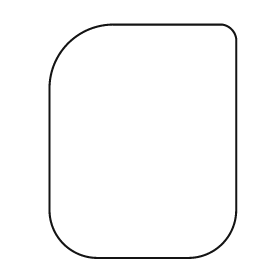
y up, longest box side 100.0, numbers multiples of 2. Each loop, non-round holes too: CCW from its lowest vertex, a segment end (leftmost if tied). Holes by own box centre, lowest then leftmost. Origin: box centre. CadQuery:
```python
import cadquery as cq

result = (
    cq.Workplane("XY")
    .moveTo(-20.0, -50.0)
    .lineTo(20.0, -50.0)
    .threePointArc((34.0, -44.0), (40.0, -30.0))
    .lineTo(40.0, 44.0)
    .threePointArc((38.0, 48.0), (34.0, 50.0))
    .lineTo(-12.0, 50.0)
    .threePointArc((-32.0, 42.0), (-40.0, 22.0))
    .lineTo(-40.0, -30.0)
    .threePointArc((-34.0, -44.0), (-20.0, -50.0))
    .close()
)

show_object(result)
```